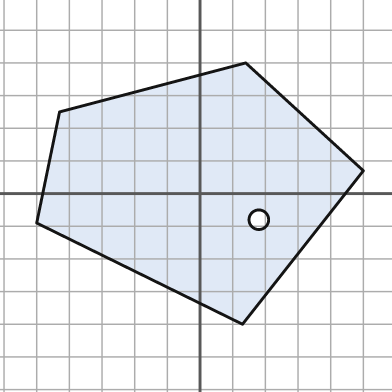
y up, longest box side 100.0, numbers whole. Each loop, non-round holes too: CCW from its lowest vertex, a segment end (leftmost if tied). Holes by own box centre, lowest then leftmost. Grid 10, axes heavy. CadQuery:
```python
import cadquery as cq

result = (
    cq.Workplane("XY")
    .moveTo(13.0, -40.0)
    .lineTo(50.0, 7.0)
    .lineTo(14.0, 40.0)
    .lineTo(-43.0, 25.0)
    .lineTo(-50.0, -9.0)
    .close()
    .moveTo(18.0, -8.0)
    .circle(3.0)
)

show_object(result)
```